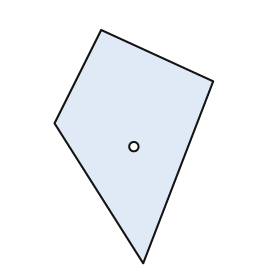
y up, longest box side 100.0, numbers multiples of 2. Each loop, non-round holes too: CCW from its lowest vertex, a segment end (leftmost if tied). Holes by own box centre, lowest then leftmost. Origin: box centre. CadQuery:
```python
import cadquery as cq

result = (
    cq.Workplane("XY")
    .moveTo(4.0, -50.0)
    .lineTo(34.0, 28.0)
    .lineTo(-14.0, 50.0)
    .lineTo(-34.0, 10.0)
    .close()
    .moveTo(0.0, 0.0)
    .circle(2.0)
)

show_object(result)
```